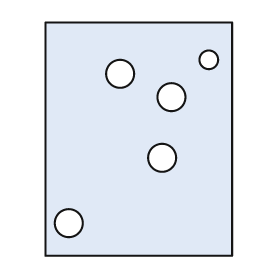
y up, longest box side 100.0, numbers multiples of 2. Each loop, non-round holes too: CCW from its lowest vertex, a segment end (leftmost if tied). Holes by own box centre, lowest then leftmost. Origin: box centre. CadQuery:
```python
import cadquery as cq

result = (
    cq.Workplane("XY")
    .moveTo(-40.0, -50.0)
    .lineTo(40.0, -50.0)
    .lineTo(40.0, 50.0)
    .lineTo(-40.0, 50.0)
    .close()
    .moveTo(-30.0, -36.0)
    .circle(6.0)
    .moveTo(10.0, -8.0)
    .circle(6.0)
    .moveTo(14.0, 18.0)
    .circle(6.0)
    .moveTo(-8.0, 28.0)
    .circle(6.0)
    .moveTo(30.0, 34.0)
    .circle(4.0)
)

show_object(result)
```